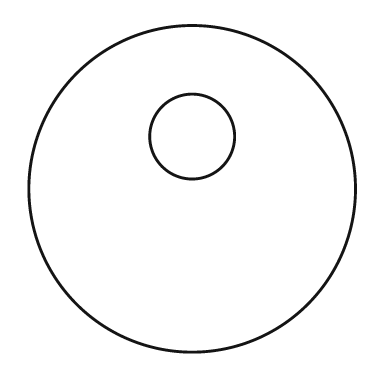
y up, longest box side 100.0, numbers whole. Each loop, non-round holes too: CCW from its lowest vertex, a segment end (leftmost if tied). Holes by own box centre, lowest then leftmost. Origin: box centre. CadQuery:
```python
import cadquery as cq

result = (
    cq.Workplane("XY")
    .moveTo(0.0, 0.0)
    .circle(50.0)
    .moveTo(0.0, 16.0)
    .circle(13.0)
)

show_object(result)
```